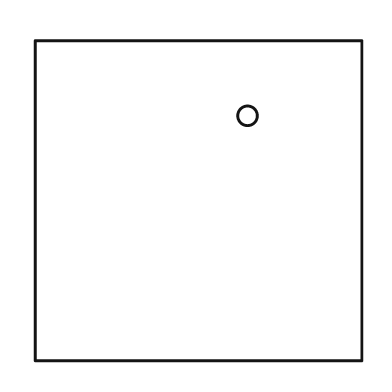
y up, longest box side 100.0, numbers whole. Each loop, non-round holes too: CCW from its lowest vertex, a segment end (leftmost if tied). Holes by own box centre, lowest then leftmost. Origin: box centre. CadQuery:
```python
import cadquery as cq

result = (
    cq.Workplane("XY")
    .moveTo(-50.0, -49.0)
    .lineTo(50.0, -49.0)
    .lineTo(50.0, 49.0)
    .lineTo(-50.0, 49.0)
    .close()
    .moveTo(15.0, 26.0)
    .circle(3.0)
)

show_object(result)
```